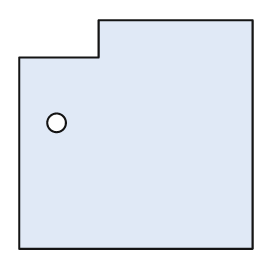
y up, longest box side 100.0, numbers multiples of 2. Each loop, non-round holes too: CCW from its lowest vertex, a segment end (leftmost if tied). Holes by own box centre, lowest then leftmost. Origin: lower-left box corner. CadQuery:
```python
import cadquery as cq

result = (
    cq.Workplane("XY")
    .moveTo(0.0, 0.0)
    .lineTo(100.0, 0.0)
    .lineTo(100.0, 98.0)
    .lineTo(34.0, 98.0)
    .lineTo(34.0, 82.0)
    .lineTo(0.0, 82.0)
    .close()
    .moveTo(16.0, 54.0)
    .circle(4.0)
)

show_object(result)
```